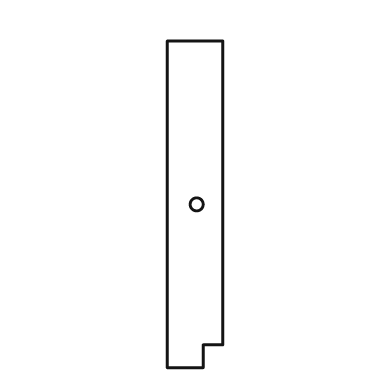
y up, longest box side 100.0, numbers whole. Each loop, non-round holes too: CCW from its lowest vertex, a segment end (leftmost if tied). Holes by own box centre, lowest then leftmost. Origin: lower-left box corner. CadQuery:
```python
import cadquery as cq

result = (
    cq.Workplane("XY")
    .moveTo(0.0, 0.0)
    .lineTo(11.0, 0.0)
    .lineTo(11.0, 7.0)
    .lineTo(17.0, 7.0)
    .lineTo(17.0, 100.0)
    .lineTo(0.0, 100.0)
    .close()
    .moveTo(9.0, 50.0)
    .circle(2.0)
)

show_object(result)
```